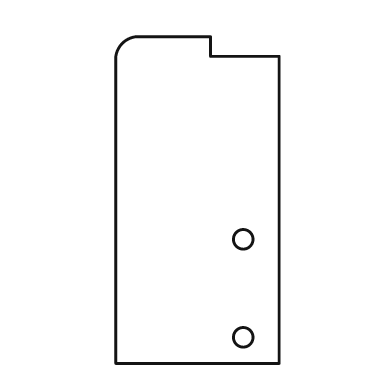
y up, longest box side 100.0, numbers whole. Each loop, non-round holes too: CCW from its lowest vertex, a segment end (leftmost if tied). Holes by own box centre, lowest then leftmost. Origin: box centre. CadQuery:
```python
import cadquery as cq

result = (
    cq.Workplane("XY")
    .moveTo(-25.0, -50.0)
    .lineTo(25.0, -50.0)
    .lineTo(25.0, 44.0)
    .lineTo(4.0, 44.0)
    .lineTo(4.0, 50.0)
    .lineTo(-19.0, 50.0)
    .threePointArc((-23.0, 48.0), (-25.0, 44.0))
    .close()
    .moveTo(14.0, -42.0)
    .circle(3.0)
    .moveTo(14.0, -12.0)
    .circle(3.0)
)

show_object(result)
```